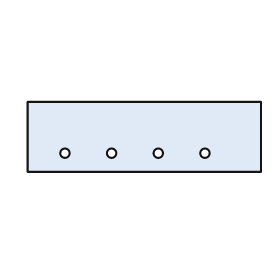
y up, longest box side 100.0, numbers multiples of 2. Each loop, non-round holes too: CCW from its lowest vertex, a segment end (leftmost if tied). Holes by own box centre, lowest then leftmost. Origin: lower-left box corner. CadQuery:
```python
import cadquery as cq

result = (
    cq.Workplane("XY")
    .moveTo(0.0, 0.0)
    .lineTo(100.0, 0.0)
    .lineTo(100.0, 30.0)
    .lineTo(0.0, 30.0)
    .close()
    .moveTo(16.0, 8.0)
    .circle(2.0)
    .moveTo(36.0, 8.0)
    .circle(2.0)
    .moveTo(56.0, 8.0)
    .circle(2.0)
    .moveTo(76.0, 8.0)
    .circle(2.0)
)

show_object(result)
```